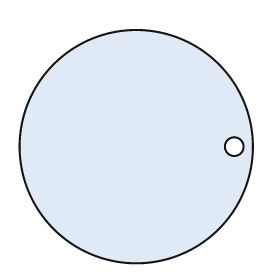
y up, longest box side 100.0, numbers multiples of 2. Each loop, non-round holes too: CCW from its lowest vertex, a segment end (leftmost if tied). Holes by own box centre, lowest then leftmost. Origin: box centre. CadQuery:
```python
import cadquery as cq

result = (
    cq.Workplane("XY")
    .moveTo(0.0, 0.0)
    .circle(50.0)
    .moveTo(42.0, 0.0)
    .circle(4.0)
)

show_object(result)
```